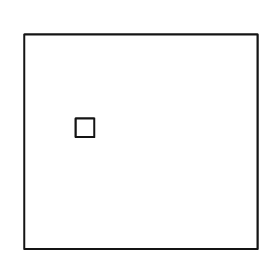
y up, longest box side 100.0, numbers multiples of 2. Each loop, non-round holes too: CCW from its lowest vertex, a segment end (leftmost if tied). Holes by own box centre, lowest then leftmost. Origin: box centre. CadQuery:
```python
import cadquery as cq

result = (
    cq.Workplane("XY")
    .moveTo(-50.0, -46.0)
    .lineTo(50.0, -46.0)
    .lineTo(50.0, 46.0)
    .lineTo(-50.0, 46.0)
    .close()
    .moveTo(-28.0, 2.0)
    .lineTo(-20.0, 2.0)
    .lineTo(-20.0, 10.0)
    .lineTo(-28.0, 10.0)
    .close()
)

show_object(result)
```